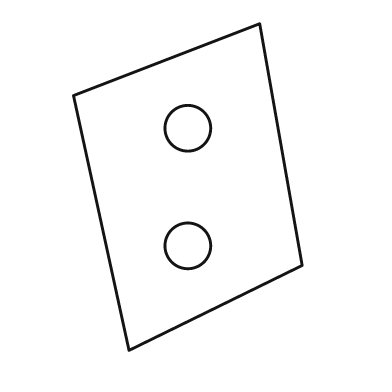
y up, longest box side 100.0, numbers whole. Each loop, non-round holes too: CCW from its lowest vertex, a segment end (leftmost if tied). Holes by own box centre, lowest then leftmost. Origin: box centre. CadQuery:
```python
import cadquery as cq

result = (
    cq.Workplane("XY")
    .moveTo(-18.0, -50.0)
    .lineTo(35.0, -24.0)
    .lineTo(22.0, 50.0)
    .lineTo(-35.0, 28.0)
    .close()
    .moveTo(0.0, -18.0)
    .circle(7.0)
    .moveTo(0.0, 18.0)
    .circle(7.0)
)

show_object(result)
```